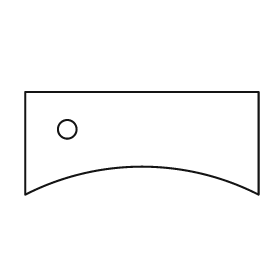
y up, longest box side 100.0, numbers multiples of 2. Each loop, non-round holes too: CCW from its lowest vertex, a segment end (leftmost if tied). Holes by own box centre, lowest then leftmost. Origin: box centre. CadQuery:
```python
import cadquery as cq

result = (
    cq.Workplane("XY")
    .moveTo(-50.0, -22.0)
    .threePointArc((0.0, -10.0), (50.0, -22.0))
    .lineTo(50.0, 22.0)
    .lineTo(-50.0, 22.0)
    .close()
    .moveTo(-32.0, 6.0)
    .circle(4.0)
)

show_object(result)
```